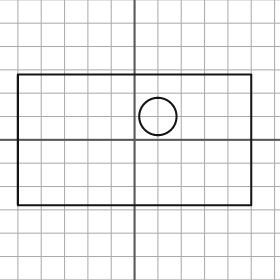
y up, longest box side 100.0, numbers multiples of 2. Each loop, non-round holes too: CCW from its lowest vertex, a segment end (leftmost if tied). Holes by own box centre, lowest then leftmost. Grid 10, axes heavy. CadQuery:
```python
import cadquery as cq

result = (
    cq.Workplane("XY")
    .moveTo(-50.0, -28.0)
    .lineTo(50.0, -28.0)
    .lineTo(50.0, 28.0)
    .lineTo(-50.0, 28.0)
    .close()
    .moveTo(10.0, 10.0)
    .circle(8.0)
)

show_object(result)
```